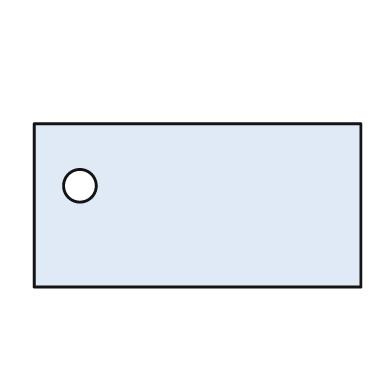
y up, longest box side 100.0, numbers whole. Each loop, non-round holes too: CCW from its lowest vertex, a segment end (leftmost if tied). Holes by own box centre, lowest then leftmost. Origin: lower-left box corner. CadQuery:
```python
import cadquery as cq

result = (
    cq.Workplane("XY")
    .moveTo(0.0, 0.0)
    .lineTo(100.0, 0.0)
    .lineTo(100.0, 50.0)
    .lineTo(0.0, 50.0)
    .close()
    .moveTo(14.0, 31.0)
    .circle(5.0)
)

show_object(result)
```